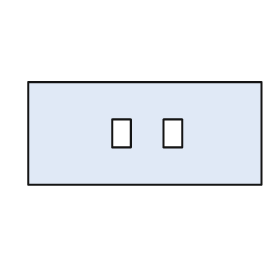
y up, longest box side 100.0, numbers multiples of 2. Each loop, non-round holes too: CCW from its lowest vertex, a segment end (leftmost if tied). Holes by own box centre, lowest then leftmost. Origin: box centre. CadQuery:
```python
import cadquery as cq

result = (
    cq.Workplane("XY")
    .moveTo(-50.0, -22.0)
    .lineTo(50.0, -22.0)
    .lineTo(50.0, 22.0)
    .lineTo(-50.0, 22.0)
    .close()
    .moveTo(-14.0, -6.0)
    .lineTo(-6.0, -6.0)
    .lineTo(-6.0, 6.0)
    .lineTo(-14.0, 6.0)
    .close()
    .moveTo(8.0, -6.0)
    .lineTo(16.0, -6.0)
    .lineTo(16.0, 6.0)
    .lineTo(8.0, 6.0)
    .close()
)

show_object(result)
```